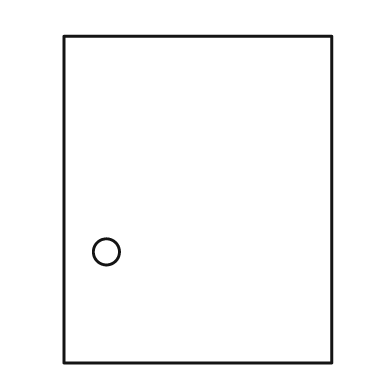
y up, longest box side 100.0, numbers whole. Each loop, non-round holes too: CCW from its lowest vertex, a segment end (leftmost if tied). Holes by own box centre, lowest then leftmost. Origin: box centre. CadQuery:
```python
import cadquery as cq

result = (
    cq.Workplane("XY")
    .moveTo(-41.0, -50.0)
    .lineTo(41.0, -50.0)
    .lineTo(41.0, 50.0)
    .lineTo(-41.0, 50.0)
    .close()
    .moveTo(-28.0, -16.0)
    .circle(4.0)
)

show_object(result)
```